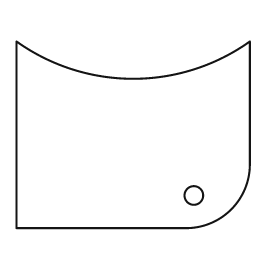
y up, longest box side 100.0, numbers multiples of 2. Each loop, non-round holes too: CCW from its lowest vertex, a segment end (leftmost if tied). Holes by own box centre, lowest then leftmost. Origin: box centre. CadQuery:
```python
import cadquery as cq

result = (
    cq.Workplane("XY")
    .moveTo(-50.0, -40.0)
    .lineTo(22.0, -40.0)
    .threePointArc((42.0, -32.0), (50.0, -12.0))
    .lineTo(50.0, 40.0)
    .threePointArc((0.0, 24.0), (-50.0, 40.0))
    .close()
    .moveTo(26.0, -26.0)
    .circle(4.0)
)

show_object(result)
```